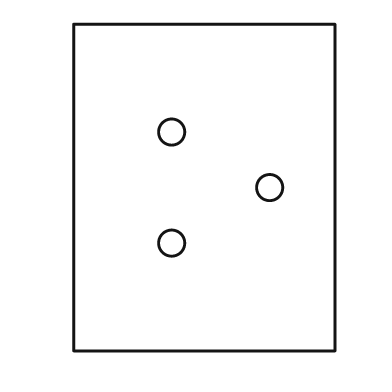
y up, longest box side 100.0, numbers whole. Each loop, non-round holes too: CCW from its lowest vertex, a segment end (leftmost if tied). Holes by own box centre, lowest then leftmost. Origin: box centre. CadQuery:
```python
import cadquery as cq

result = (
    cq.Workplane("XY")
    .moveTo(-40.0, -50.0)
    .lineTo(40.0, -50.0)
    .lineTo(40.0, 50.0)
    .lineTo(-40.0, 50.0)
    .close()
    .moveTo(-10.0, -17.0)
    .circle(4.0)
    .moveTo(20.0, 0.0)
    .circle(4.0)
    .moveTo(-10.0, 17.0)
    .circle(4.0)
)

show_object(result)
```